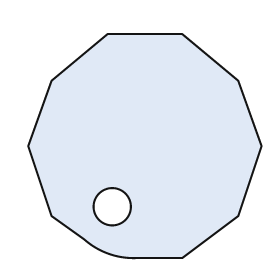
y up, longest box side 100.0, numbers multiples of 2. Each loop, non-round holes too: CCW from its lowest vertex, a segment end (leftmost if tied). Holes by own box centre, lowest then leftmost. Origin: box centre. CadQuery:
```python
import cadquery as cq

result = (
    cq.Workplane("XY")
    .moveTo(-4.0, -48.0)
    .lineTo(16.0, -48.0)
    .lineTo(40.0, -30.0)
    .lineTo(50.0, 0.0)
    .lineTo(40.0, 28.0)
    .lineTo(16.0, 48.0)
    .lineTo(-16.0, 48.0)
    .lineTo(-40.0, 28.0)
    .lineTo(-50.0, 0.0)
    .lineTo(-40.0, -30.0)
    .lineTo(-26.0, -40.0)
    .threePointArc((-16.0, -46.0), (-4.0, -48.0))
    .close()
    .moveTo(-14.0, -26.0)
    .circle(8.0)
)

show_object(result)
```